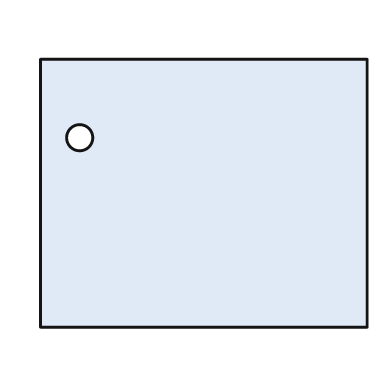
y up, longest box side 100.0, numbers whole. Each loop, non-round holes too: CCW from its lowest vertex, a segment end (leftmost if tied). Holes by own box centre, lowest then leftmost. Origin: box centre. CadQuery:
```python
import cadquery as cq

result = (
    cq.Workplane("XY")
    .moveTo(-50.0, -41.0)
    .lineTo(50.0, -41.0)
    .lineTo(50.0, 41.0)
    .lineTo(-50.0, 41.0)
    .close()
    .moveTo(-38.0, 17.0)
    .circle(4.0)
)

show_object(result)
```